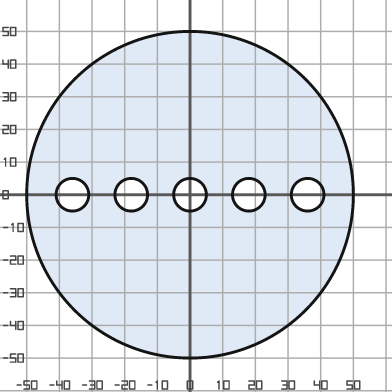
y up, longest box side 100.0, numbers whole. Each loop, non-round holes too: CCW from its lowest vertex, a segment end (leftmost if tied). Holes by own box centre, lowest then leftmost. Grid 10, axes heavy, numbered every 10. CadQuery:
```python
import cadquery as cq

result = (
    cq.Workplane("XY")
    .moveTo(0.0, 0.0)
    .circle(50.0)
    .moveTo(-36.0, 0.0)
    .circle(5.0)
    .moveTo(-18.0, 0.0)
    .circle(5.0)
    .moveTo(0.0, 0.0)
    .circle(5.0)
    .moveTo(18.0, 0.0)
    .circle(5.0)
    .moveTo(36.0, 0.0)
    .circle(5.0)
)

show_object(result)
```